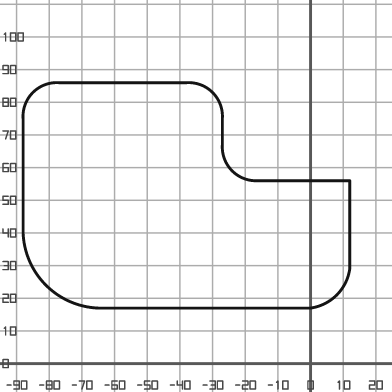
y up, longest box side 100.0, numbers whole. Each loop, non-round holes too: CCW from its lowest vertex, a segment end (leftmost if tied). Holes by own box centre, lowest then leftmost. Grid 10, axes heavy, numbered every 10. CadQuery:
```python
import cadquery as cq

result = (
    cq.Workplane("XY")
    .moveTo(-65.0, 17.0)
    .lineTo(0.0, 17.0)
    .threePointArc((8.0, 21.0), (12.0, 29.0))
    .lineTo(12.0, 56.0)
    .lineTo(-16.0, 56.0)
    .threePointArc((-24.0, 59.0), (-27.0, 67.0))
    .lineTo(-27.0, 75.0)
    .threePointArc((-30.0, 83.0), (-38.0, 86.0))
    .lineTo(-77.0, 86.0)
    .threePointArc((-85.0, 83.0), (-88.0, 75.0))
    .lineTo(-88.0, 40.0)
    .threePointArc((-81.0, 24.0), (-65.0, 17.0))
    .close()
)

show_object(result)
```